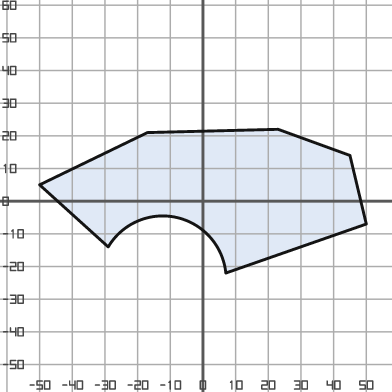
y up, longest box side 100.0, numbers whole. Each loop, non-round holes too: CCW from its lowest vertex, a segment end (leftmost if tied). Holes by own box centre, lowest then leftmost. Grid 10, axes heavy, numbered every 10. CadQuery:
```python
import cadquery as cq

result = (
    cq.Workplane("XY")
    .moveTo(7.0, -22.0)
    .lineTo(50.0, -7.0)
    .lineTo(45.0, 14.0)
    .lineTo(23.0, 22.0)
    .lineTo(-17.0, 21.0)
    .lineTo(-50.0, 5.0)
    .lineTo(-29.0, -14.0)
    .threePointArc((-8.0, -5.0), (7.0, -22.0))
    .close()
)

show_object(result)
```